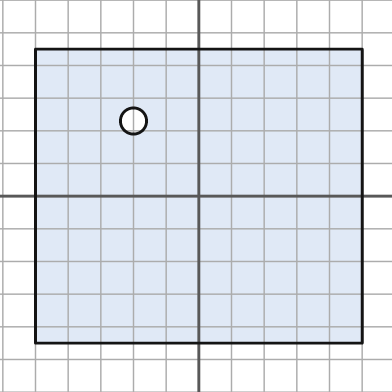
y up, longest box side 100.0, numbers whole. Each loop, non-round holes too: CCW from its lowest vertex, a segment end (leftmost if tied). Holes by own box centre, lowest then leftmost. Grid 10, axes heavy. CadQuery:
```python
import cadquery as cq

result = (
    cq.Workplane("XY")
    .moveTo(-50.0, -45.0)
    .lineTo(50.0, -45.0)
    .lineTo(50.0, 45.0)
    .lineTo(-50.0, 45.0)
    .close()
    .moveTo(-20.0, 23.0)
    .circle(4.0)
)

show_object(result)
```